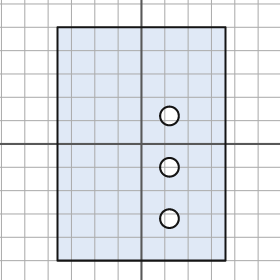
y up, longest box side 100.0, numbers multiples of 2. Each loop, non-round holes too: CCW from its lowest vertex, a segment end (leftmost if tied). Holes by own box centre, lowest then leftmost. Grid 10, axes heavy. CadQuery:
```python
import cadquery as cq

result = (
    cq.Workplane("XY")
    .moveTo(-36.0, -50.0)
    .lineTo(36.0, -50.0)
    .lineTo(36.0, 50.0)
    .lineTo(-36.0, 50.0)
    .close()
    .moveTo(12.0, -32.0)
    .circle(4.0)
    .moveTo(12.0, -10.0)
    .circle(4.0)
    .moveTo(12.0, 12.0)
    .circle(4.0)
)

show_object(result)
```